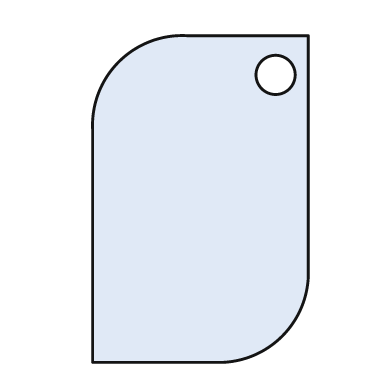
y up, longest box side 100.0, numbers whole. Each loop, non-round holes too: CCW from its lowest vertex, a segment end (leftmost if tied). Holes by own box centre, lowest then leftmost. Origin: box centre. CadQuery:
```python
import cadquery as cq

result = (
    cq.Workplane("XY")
    .moveTo(-33.0, -50.0)
    .lineTo(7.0, -50.0)
    .threePointArc((25.0, -42.0), (33.0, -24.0))
    .lineTo(33.0, 50.0)
    .lineTo(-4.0, 50.0)
    .threePointArc((-25.0, 42.0), (-33.0, 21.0))
    .close()
    .moveTo(23.0, 38.0)
    .circle(6.0)
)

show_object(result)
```